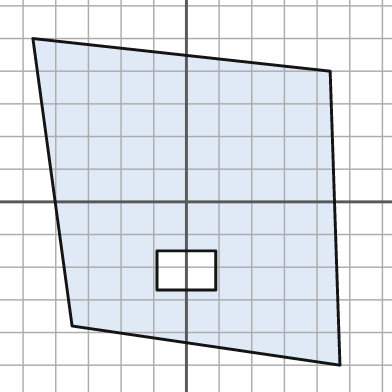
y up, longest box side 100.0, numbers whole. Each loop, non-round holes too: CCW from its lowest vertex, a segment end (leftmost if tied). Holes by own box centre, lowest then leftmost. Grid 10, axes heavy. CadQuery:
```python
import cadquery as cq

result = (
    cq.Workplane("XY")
    .moveTo(47.0, -50.0)
    .lineTo(44.0, 40.0)
    .lineTo(-47.0, 50.0)
    .lineTo(-35.0, -38.0)
    .close()
    .moveTo(-9.0, -27.0)
    .lineTo(9.0, -27.0)
    .lineTo(9.0, -15.0)
    .lineTo(-9.0, -15.0)
    .close()
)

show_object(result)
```